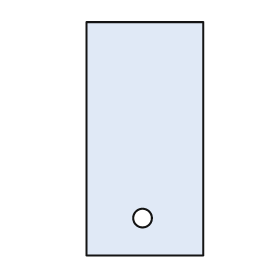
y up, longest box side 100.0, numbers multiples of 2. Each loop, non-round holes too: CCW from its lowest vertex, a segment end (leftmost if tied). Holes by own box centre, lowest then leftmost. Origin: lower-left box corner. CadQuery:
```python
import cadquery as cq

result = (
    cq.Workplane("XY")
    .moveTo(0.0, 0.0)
    .lineTo(50.0, 0.0)
    .lineTo(50.0, 100.0)
    .lineTo(0.0, 100.0)
    .close()
    .moveTo(24.0, 16.0)
    .circle(4.0)
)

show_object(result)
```